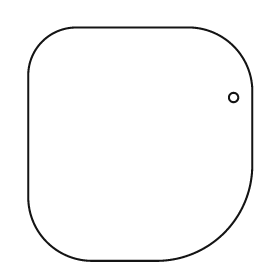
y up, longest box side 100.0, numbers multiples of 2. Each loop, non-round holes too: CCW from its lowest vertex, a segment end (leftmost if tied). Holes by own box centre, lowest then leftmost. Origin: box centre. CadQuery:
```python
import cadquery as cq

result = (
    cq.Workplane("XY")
    .moveTo(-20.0, -50.0)
    .lineTo(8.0, -50.0)
    .threePointArc((36.0, -38.0), (48.0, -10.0))
    .lineTo(48.0, 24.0)
    .threePointArc((40.0, 42.0), (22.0, 50.0))
    .lineTo(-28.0, 50.0)
    .threePointArc((-42.0, 44.0), (-48.0, 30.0))
    .lineTo(-48.0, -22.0)
    .threePointArc((-40.0, -42.0), (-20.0, -50.0))
    .close()
    .moveTo(40.0, 20.0)
    .circle(2.0)
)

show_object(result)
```